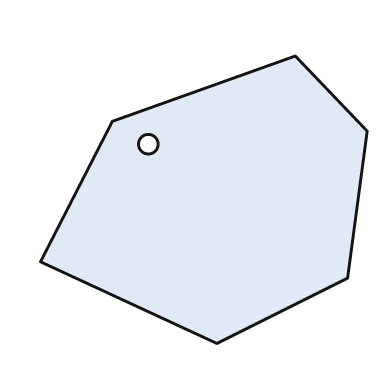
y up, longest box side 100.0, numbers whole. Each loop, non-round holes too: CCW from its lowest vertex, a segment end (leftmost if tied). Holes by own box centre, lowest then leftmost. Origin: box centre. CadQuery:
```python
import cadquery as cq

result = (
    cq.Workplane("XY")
    .moveTo(4.0, -44.0)
    .lineTo(44.0, -24.0)
    .lineTo(50.0, 21.0)
    .lineTo(28.0, 44.0)
    .lineTo(-28.0, 24.0)
    .lineTo(-50.0, -19.0)
    .close()
    .moveTo(-17.0, 17.0)
    .circle(3.0)
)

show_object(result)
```